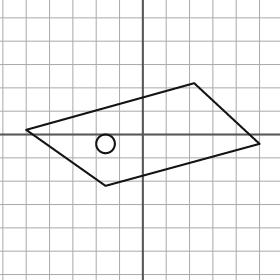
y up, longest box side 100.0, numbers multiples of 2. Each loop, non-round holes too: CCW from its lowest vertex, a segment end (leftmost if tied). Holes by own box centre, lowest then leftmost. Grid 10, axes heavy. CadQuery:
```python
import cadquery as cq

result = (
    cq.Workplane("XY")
    .moveTo(-16.0, -22.0)
    .lineTo(50.0, -4.0)
    .lineTo(22.0, 22.0)
    .lineTo(-50.0, 2.0)
    .close()
    .moveTo(-16.0, -4.0)
    .circle(4.0)
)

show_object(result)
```